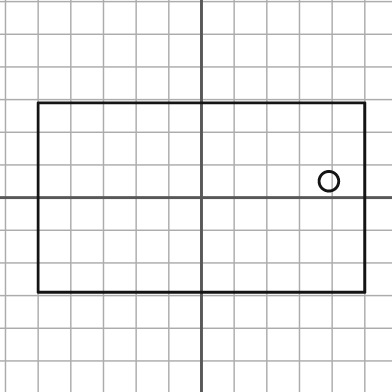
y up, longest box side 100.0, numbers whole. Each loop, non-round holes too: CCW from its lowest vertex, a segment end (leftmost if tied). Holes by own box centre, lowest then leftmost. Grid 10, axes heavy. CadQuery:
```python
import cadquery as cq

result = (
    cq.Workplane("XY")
    .moveTo(-50.0, -29.0)
    .lineTo(50.0, -29.0)
    .lineTo(50.0, 29.0)
    .lineTo(-50.0, 29.0)
    .close()
    .moveTo(39.0, 5.0)
    .circle(3.0)
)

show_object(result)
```